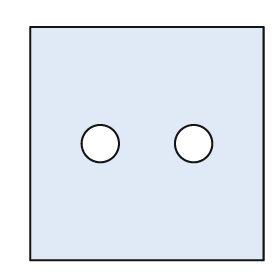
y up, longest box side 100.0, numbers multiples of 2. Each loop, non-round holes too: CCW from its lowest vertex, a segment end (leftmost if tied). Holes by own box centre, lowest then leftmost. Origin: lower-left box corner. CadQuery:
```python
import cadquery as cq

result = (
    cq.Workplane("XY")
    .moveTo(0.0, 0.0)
    .lineTo(100.0, 0.0)
    .lineTo(100.0, 100.0)
    .lineTo(0.0, 100.0)
    .close()
    .moveTo(30.0, 50.0)
    .circle(8.0)
    .moveTo(70.0, 50.0)
    .circle(8.0)
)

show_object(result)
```